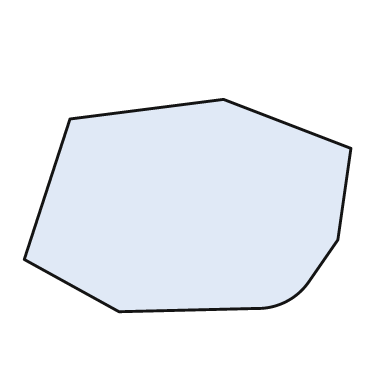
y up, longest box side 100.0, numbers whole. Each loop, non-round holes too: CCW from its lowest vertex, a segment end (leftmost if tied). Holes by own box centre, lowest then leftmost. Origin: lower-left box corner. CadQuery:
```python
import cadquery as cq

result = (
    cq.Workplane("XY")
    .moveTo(29.0, 0.0)
    .lineTo(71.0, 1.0)
    .threePointArc((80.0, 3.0), (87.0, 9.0))
    .lineTo(96.0, 22.0)
    .lineTo(100.0, 50.0)
    .lineTo(61.0, 65.0)
    .lineTo(14.0, 59.0)
    .lineTo(0.0, 16.0)
    .close()
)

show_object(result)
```